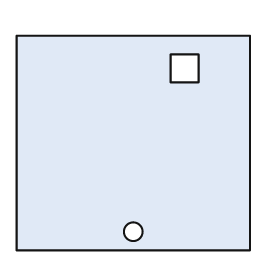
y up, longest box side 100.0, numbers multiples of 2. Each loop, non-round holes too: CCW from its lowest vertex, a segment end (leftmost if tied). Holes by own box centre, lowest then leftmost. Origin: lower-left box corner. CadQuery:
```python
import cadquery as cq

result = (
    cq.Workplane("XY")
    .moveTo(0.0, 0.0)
    .lineTo(100.0, 0.0)
    .lineTo(100.0, 92.0)
    .lineTo(0.0, 92.0)
    .close()
    .moveTo(50.0, 8.0)
    .circle(4.0)
    .moveTo(66.0, 72.0)
    .lineTo(78.0, 72.0)
    .lineTo(78.0, 84.0)
    .lineTo(66.0, 84.0)
    .close()
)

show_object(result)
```